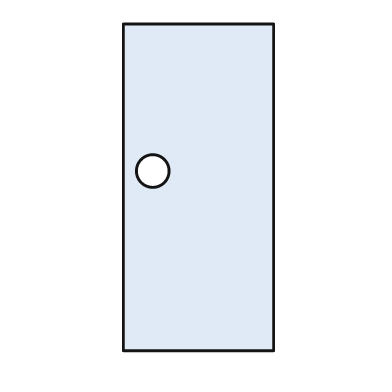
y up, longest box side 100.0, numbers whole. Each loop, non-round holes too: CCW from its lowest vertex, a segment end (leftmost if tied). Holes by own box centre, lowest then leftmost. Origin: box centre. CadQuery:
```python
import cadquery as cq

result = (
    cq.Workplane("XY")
    .moveTo(-23.0, -50.0)
    .lineTo(23.0, -50.0)
    .lineTo(23.0, 50.0)
    .lineTo(-23.0, 50.0)
    .close()
    .moveTo(-14.0, 5.0)
    .circle(5.0)
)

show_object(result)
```